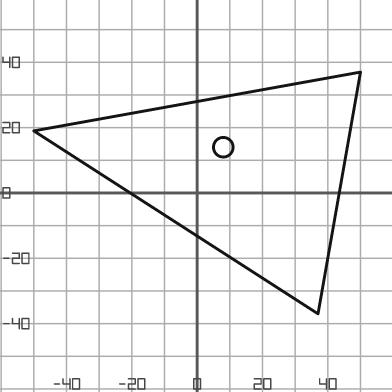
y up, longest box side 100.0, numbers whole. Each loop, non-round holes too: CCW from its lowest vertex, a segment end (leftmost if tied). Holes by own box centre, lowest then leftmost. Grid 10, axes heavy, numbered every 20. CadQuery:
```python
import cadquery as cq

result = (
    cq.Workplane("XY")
    .moveTo(37.0, -37.0)
    .lineTo(50.0, 37.0)
    .lineTo(-50.0, 19.0)
    .close()
    .moveTo(8.0, 14.0)
    .circle(3.0)
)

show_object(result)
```